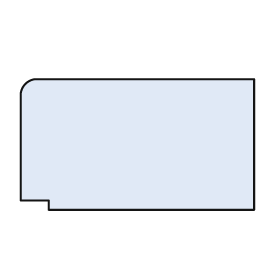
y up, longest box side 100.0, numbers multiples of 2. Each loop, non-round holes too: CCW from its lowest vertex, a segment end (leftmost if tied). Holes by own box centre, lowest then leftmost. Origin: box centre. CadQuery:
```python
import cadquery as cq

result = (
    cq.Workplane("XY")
    .moveTo(-38.0, -28.0)
    .lineTo(50.0, -28.0)
    .lineTo(50.0, 28.0)
    .lineTo(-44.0, 28.0)
    .threePointArc((-48.0, 26.0), (-50.0, 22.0))
    .lineTo(-50.0, -24.0)
    .lineTo(-38.0, -24.0)
    .close()
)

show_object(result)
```